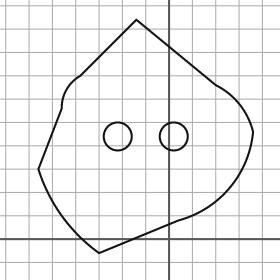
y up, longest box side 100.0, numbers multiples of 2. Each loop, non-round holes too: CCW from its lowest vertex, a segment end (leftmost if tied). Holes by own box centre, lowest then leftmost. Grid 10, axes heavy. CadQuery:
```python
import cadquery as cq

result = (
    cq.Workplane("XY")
    .moveTo(-30.0, -6.0)
    .lineTo(4.0, 8.0)
    .threePointArc((26.0, 22.0), (36.0, 46.0))
    .threePointArc((30.0, 58.0), (20.0, 66.0))
    .lineTo(-14.0, 94.0)
    .lineTo(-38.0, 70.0)
    .threePointArc((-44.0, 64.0), (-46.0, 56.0))
    .lineTo(-56.0, 30.0)
    .threePointArc((-46.0, 10.0), (-30.0, -6.0))
    .close()
    .moveTo(-22.0, 44.0)
    .circle(6.0)
    .moveTo(2.0, 44.0)
    .circle(6.0)
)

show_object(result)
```